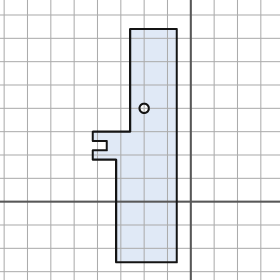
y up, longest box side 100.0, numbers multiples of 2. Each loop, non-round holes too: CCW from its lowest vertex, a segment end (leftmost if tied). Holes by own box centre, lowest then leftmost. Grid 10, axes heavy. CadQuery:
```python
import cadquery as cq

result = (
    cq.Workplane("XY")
    .moveTo(-32.0, -26.0)
    .lineTo(-6.0, -26.0)
    .lineTo(-6.0, 74.0)
    .lineTo(-26.0, 74.0)
    .lineTo(-26.0, 30.0)
    .lineTo(-42.0, 30.0)
    .lineTo(-42.0, 26.0)
    .lineTo(-36.0, 26.0)
    .lineTo(-36.0, 22.0)
    .lineTo(-42.0, 22.0)
    .lineTo(-42.0, 18.0)
    .lineTo(-32.0, 18.0)
    .close()
    .moveTo(-20.0, 40.0)
    .circle(2.0)
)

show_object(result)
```